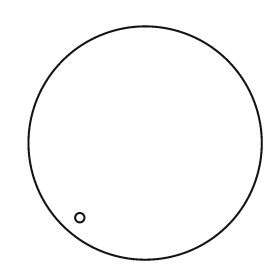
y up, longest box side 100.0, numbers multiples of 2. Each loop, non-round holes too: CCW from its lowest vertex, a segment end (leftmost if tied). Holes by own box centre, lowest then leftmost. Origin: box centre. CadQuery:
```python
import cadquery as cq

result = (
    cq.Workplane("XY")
    .moveTo(0.0, 0.0)
    .circle(50.0)
    .moveTo(-28.0, -32.0)
    .circle(2.0)
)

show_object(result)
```